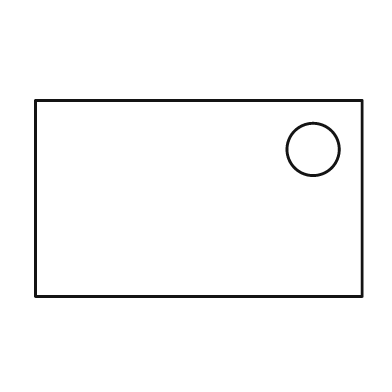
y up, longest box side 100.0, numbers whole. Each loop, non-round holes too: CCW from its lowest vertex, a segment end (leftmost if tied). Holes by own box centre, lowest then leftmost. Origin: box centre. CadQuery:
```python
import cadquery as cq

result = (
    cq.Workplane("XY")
    .moveTo(-50.0, -30.0)
    .lineTo(50.0, -30.0)
    .lineTo(50.0, 30.0)
    .lineTo(-50.0, 30.0)
    .close()
    .moveTo(35.0, 15.0)
    .circle(8.0)
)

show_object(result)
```